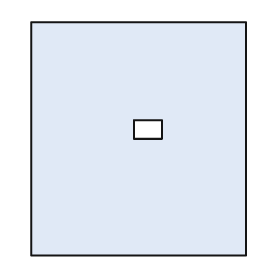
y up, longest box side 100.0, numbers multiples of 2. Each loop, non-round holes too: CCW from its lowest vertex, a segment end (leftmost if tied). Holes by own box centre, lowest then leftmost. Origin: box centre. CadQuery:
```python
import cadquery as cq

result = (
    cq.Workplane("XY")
    .moveTo(-46.0, -50.0)
    .lineTo(46.0, -50.0)
    .lineTo(46.0, 50.0)
    .lineTo(-46.0, 50.0)
    .close()
    .moveTo(-2.0, 0.0)
    .lineTo(10.0, 0.0)
    .lineTo(10.0, 8.0)
    .lineTo(-2.0, 8.0)
    .close()
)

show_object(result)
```